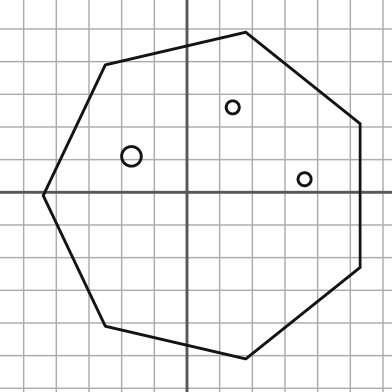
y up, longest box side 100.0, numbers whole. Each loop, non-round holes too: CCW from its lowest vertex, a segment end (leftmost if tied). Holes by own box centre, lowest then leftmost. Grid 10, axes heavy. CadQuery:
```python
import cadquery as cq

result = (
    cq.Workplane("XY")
    .moveTo(18.0, -51.0)
    .lineTo(53.0, -23.0)
    .lineTo(53.0, 21.0)
    .lineTo(18.0, 49.0)
    .lineTo(-25.0, 39.0)
    .lineTo(-44.0, -1.0)
    .lineTo(-25.0, -41.0)
    .close()
    .moveTo(36.0, 4.0)
    .circle(2.0)
    .moveTo(-17.0, 11.0)
    .circle(3.0)
    .moveTo(14.0, 26.0)
    .circle(2.0)
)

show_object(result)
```